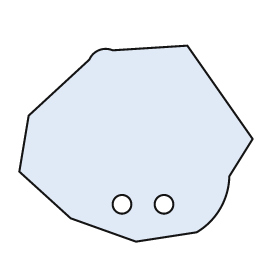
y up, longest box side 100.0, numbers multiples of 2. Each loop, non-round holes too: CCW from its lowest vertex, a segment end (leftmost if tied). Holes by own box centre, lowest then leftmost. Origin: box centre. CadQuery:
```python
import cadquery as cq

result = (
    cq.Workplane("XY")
    .moveTo(0.0, -42.0)
    .lineTo(26.0, -38.0)
    .threePointArc((36.0, -28.0), (40.0, -14.0))
    .lineTo(50.0, 2.0)
    .lineTo(22.0, 42.0)
    .lineTo(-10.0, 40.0)
    .threePointArc((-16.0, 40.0), (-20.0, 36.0))
    .lineTo(-46.0, 12.0)
    .lineTo(-50.0, -12.0)
    .lineTo(-28.0, -32.0)
    .close()
    .moveTo(-6.0, -26.0)
    .circle(4.0)
    .moveTo(12.0, -26.0)
    .circle(4.0)
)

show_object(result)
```